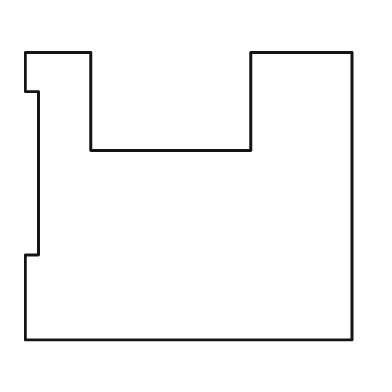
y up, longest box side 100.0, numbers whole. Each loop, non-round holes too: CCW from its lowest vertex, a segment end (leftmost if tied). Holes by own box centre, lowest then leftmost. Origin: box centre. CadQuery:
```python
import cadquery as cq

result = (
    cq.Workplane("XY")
    .moveTo(-50.0, -44.0)
    .lineTo(50.0, -44.0)
    .lineTo(50.0, 44.0)
    .lineTo(19.0, 44.0)
    .lineTo(19.0, 14.0)
    .lineTo(-30.0, 14.0)
    .lineTo(-30.0, 44.0)
    .lineTo(-50.0, 44.0)
    .lineTo(-50.0, 32.0)
    .lineTo(-46.0, 32.0)
    .lineTo(-46.0, -18.0)
    .lineTo(-50.0, -18.0)
    .close()
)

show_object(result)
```